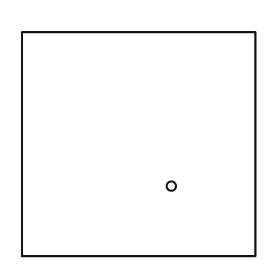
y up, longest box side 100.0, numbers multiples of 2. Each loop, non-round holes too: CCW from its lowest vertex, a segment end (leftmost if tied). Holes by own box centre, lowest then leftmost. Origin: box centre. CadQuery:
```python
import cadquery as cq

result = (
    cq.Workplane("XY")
    .moveTo(-50.0, -48.0)
    .lineTo(50.0, -48.0)
    .lineTo(50.0, 48.0)
    .lineTo(-50.0, 48.0)
    .close()
    .moveTo(14.0, -18.0)
    .circle(2.0)
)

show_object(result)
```